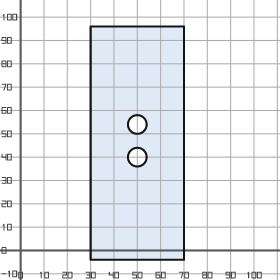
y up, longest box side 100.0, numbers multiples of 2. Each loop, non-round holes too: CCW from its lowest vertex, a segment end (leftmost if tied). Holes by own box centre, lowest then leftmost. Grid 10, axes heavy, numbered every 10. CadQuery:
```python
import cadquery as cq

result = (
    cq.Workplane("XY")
    .moveTo(30.0, -4.0)
    .lineTo(70.0, -4.0)
    .lineTo(70.0, 96.0)
    .lineTo(30.0, 96.0)
    .close()
    .moveTo(50.0, 40.0)
    .circle(4.0)
    .moveTo(50.0, 54.0)
    .circle(4.0)
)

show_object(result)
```